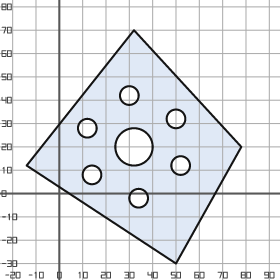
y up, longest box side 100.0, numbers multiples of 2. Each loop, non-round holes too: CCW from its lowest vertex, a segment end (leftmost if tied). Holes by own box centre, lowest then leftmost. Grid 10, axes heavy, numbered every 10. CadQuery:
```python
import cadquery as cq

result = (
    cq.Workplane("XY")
    .moveTo(50.0, -30.0)
    .lineTo(78.0, 20.0)
    .lineTo(32.0, 70.0)
    .lineTo(-14.0, 12.0)
    .close()
    .moveTo(34.0, -2.0)
    .circle(4.0)
    .moveTo(14.0, 8.0)
    .circle(4.0)
    .moveTo(52.0, 12.0)
    .circle(4.0)
    .moveTo(32.0, 20.0)
    .circle(8.0)
    .moveTo(12.0, 28.0)
    .circle(4.0)
    .moveTo(50.0, 32.0)
    .circle(4.0)
    .moveTo(30.0, 42.0)
    .circle(4.0)
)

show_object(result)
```